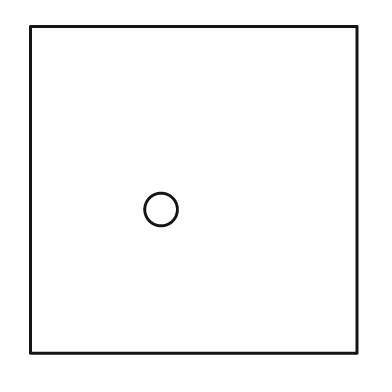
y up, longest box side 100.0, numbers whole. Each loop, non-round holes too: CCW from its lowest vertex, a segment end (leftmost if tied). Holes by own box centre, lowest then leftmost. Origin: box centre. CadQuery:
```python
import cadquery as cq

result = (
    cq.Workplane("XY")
    .moveTo(-50.0, -50.0)
    .lineTo(50.0, -50.0)
    .lineTo(50.0, 50.0)
    .lineTo(-50.0, 50.0)
    .close()
    .moveTo(-10.0, -6.0)
    .circle(5.0)
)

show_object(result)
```